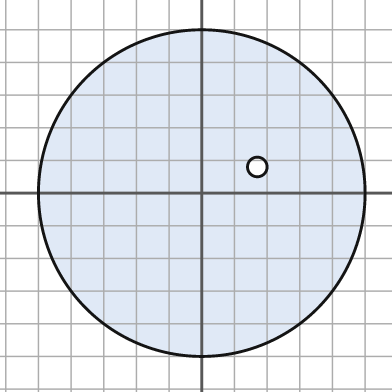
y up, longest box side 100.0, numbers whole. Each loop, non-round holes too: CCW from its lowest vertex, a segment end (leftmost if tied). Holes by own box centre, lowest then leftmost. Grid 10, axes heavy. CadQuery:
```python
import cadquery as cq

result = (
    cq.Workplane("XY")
    .moveTo(0.0, 0.0)
    .circle(50.0)
    .moveTo(17.0, 8.0)
    .circle(3.0)
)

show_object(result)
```